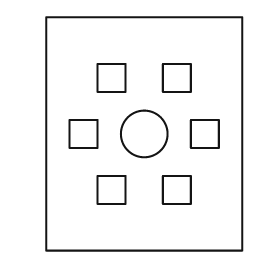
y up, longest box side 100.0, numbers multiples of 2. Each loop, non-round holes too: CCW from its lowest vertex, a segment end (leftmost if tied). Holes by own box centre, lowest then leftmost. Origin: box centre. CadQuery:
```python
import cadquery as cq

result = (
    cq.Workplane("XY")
    .moveTo(-42.0, -50.0)
    .lineTo(42.0, -50.0)
    .lineTo(42.0, 50.0)
    .lineTo(-42.0, 50.0)
    .close()
    .moveTo(-20.0, -30.0)
    .lineTo(-8.0, -30.0)
    .lineTo(-8.0, -18.0)
    .lineTo(-20.0, -18.0)
    .close()
    .moveTo(8.0, -30.0)
    .lineTo(20.0, -30.0)
    .lineTo(20.0, -18.0)
    .lineTo(8.0, -18.0)
    .close()
    .moveTo(-32.0, -6.0)
    .lineTo(-20.0, -6.0)
    .lineTo(-20.0, 6.0)
    .lineTo(-32.0, 6.0)
    .close()
    .moveTo(0.0, 0.0)
    .circle(10.0)
    .moveTo(20.0, -6.0)
    .lineTo(32.0, -6.0)
    .lineTo(32.0, 6.0)
    .lineTo(20.0, 6.0)
    .close()
    .moveTo(-20.0, 18.0)
    .lineTo(-8.0, 18.0)
    .lineTo(-8.0, 30.0)
    .lineTo(-20.0, 30.0)
    .close()
    .moveTo(8.0, 18.0)
    .lineTo(20.0, 18.0)
    .lineTo(20.0, 30.0)
    .lineTo(8.0, 30.0)
    .close()
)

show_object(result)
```